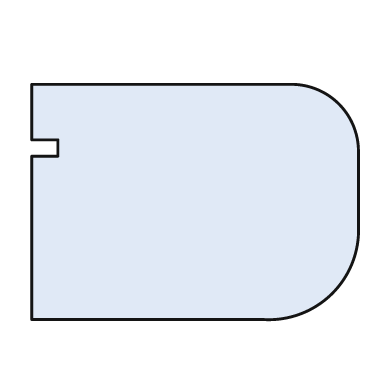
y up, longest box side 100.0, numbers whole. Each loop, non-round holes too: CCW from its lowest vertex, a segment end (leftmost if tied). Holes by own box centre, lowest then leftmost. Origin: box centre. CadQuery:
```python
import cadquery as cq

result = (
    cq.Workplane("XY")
    .moveTo(-50.0, -36.0)
    .lineTo(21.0, -36.0)
    .threePointArc((42.0, -28.0), (50.0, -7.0))
    .lineTo(50.0, 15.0)
    .threePointArc((44.0, 30.0), (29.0, 36.0))
    .lineTo(-50.0, 36.0)
    .lineTo(-50.0, 19.0)
    .lineTo(-42.0, 19.0)
    .lineTo(-42.0, 14.0)
    .lineTo(-50.0, 14.0)
    .close()
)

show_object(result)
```